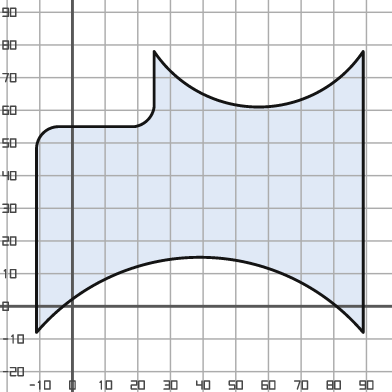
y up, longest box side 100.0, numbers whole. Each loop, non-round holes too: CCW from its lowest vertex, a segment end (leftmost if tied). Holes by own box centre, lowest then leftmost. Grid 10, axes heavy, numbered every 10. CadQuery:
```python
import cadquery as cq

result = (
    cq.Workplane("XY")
    .moveTo(-11.0, -8.0)
    .threePointArc((39.0, 15.0), (89.0, -8.0))
    .lineTo(89.0, 78.0)
    .threePointArc((57.0, 61.0), (25.0, 78.0))
    .lineTo(25.0, 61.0)
    .threePointArc((23.0, 57.0), (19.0, 55.0))
    .lineTo(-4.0, 55.0)
    .threePointArc((-9.0, 53.0), (-11.0, 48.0))
    .close()
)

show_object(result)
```